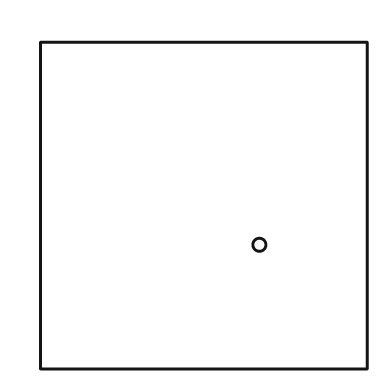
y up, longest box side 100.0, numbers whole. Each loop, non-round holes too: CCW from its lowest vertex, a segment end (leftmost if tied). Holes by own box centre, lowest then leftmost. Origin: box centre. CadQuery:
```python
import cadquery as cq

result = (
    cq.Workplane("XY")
    .moveTo(-50.0, -50.0)
    .lineTo(50.0, -50.0)
    .lineTo(50.0, 50.0)
    .lineTo(-50.0, 50.0)
    .close()
    .moveTo(17.0, -12.0)
    .circle(2.0)
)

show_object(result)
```